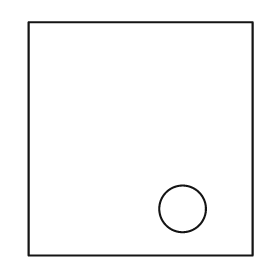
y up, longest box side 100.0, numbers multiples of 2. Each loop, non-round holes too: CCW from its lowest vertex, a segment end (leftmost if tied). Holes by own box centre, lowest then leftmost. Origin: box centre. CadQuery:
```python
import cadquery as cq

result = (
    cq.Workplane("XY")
    .moveTo(-48.0, -50.0)
    .lineTo(48.0, -50.0)
    .lineTo(48.0, 50.0)
    .lineTo(-48.0, 50.0)
    .close()
    .moveTo(18.0, -30.0)
    .circle(10.0)
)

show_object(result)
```